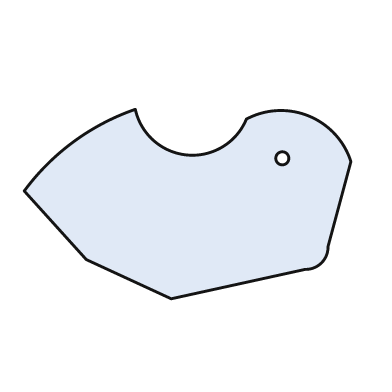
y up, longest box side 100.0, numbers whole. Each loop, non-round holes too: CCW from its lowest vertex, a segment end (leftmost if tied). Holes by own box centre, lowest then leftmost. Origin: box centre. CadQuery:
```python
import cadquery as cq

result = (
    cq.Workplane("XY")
    .moveTo(-5.0, -29.0)
    .lineTo(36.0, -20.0)
    .threePointArc((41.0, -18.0), (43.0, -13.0))
    .lineTo(50.0, 13.0)
    .threePointArc((37.0, 27.0), (18.0, 26.0))
    .threePointArc((0.0, 15.0), (-16.0, 29.0))
    .threePointArc((-35.0, 19.0), (-50.0, 4.0))
    .lineTo(-31.0, -17.0)
    .close()
    .moveTo(29.0, 14.0)
    .circle(2.0)
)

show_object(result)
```